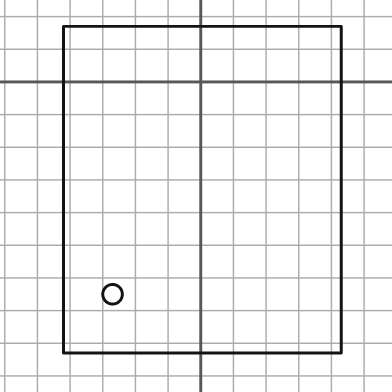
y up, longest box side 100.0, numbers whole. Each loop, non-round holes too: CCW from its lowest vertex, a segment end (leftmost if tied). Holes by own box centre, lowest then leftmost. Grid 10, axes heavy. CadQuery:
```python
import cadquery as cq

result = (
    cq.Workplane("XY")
    .moveTo(-42.0, -83.0)
    .lineTo(43.0, -83.0)
    .lineTo(43.0, 17.0)
    .lineTo(-42.0, 17.0)
    .close()
    .moveTo(-27.0, -65.0)
    .circle(3.0)
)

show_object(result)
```